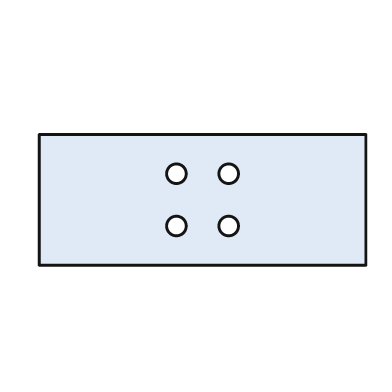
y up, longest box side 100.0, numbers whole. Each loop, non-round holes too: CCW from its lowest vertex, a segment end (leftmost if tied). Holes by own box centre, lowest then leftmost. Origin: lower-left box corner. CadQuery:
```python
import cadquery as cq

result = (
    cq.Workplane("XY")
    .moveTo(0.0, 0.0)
    .lineTo(100.0, 0.0)
    .lineTo(100.0, 40.0)
    .lineTo(0.0, 40.0)
    .close()
    .moveTo(42.0, 12.0)
    .circle(3.0)
    .moveTo(58.0, 12.0)
    .circle(3.0)
    .moveTo(42.0, 28.0)
    .circle(3.0)
    .moveTo(58.0, 28.0)
    .circle(3.0)
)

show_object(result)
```